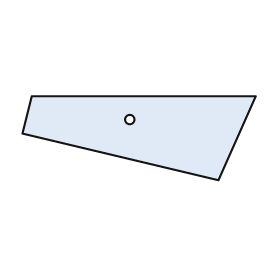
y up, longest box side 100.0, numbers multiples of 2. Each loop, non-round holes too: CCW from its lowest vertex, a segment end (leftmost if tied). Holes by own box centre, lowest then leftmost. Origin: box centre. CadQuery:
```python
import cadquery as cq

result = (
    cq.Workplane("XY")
    .moveTo(34.0, -18.0)
    .lineTo(50.0, 18.0)
    .lineTo(-46.0, 18.0)
    .lineTo(-50.0, 2.0)
    .close()
    .moveTo(-4.0, 8.0)
    .circle(2.0)
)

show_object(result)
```